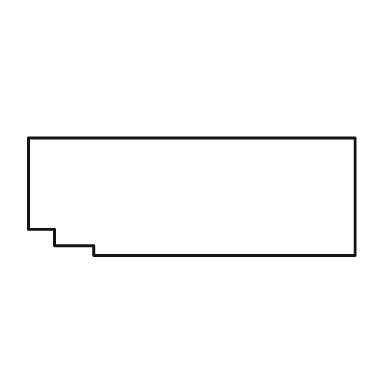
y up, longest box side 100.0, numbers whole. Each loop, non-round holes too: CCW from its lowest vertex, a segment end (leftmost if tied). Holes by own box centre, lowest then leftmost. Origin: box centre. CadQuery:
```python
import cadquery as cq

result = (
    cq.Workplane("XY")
    .moveTo(-30.0, -18.0)
    .lineTo(50.0, -18.0)
    .lineTo(50.0, 18.0)
    .lineTo(-50.0, 18.0)
    .lineTo(-50.0, -10.0)
    .lineTo(-42.0, -10.0)
    .lineTo(-42.0, -15.0)
    .lineTo(-30.0, -15.0)
    .close()
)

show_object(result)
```